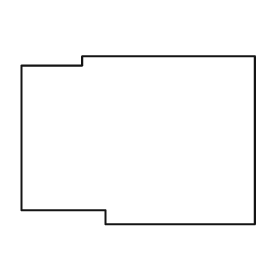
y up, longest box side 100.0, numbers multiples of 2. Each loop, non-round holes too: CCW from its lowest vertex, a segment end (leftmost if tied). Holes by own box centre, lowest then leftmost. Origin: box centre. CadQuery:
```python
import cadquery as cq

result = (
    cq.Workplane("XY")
    .moveTo(-14.0, -36.0)
    .lineTo(50.0, -36.0)
    .lineTo(50.0, 36.0)
    .lineTo(-24.0, 36.0)
    .lineTo(-24.0, 32.0)
    .lineTo(-50.0, 32.0)
    .lineTo(-50.0, -30.0)
    .lineTo(-14.0, -30.0)
    .close()
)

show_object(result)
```